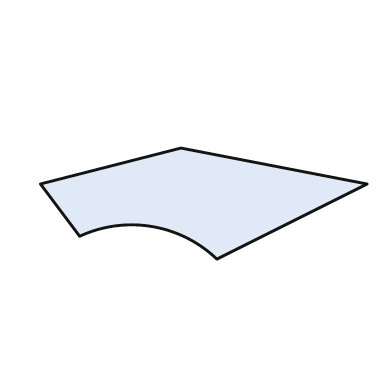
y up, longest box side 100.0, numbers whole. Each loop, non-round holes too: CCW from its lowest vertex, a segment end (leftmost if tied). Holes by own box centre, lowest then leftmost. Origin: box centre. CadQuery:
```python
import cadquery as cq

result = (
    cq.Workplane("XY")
    .moveTo(4.0, -17.0)
    .lineTo(50.0, 6.0)
    .lineTo(-7.0, 17.0)
    .lineTo(-50.0, 6.0)
    .lineTo(-38.0, -10.0)
    .threePointArc((-16.0, -7.0), (4.0, -17.0))
    .close()
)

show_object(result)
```